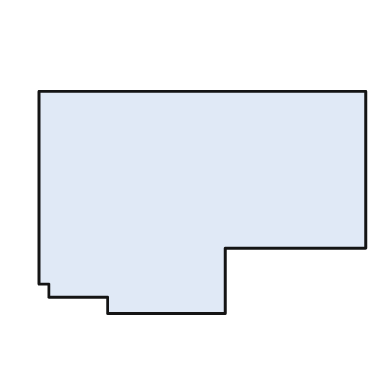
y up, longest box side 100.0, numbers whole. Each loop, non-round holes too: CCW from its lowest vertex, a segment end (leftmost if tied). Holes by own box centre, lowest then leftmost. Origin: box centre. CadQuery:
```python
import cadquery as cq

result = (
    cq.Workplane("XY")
    .moveTo(-29.0, -34.0)
    .lineTo(7.0, -34.0)
    .lineTo(7.0, -14.0)
    .lineTo(50.0, -14.0)
    .lineTo(50.0, 34.0)
    .lineTo(-50.0, 34.0)
    .lineTo(-50.0, -25.0)
    .lineTo(-47.0, -25.0)
    .lineTo(-47.0, -29.0)
    .lineTo(-29.0, -29.0)
    .close()
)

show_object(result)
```